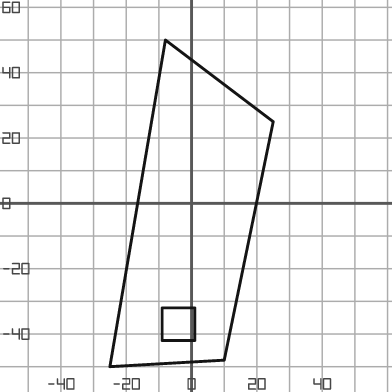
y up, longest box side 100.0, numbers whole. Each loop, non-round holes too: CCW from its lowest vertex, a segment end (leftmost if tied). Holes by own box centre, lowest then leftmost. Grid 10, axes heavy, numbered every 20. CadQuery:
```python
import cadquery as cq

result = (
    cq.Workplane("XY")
    .moveTo(-25.0, -50.0)
    .lineTo(10.0, -48.0)
    .lineTo(25.0, 25.0)
    .lineTo(-8.0, 50.0)
    .close()
    .moveTo(-9.0, -42.0)
    .lineTo(1.0, -42.0)
    .lineTo(1.0, -32.0)
    .lineTo(-9.0, -32.0)
    .close()
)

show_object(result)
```